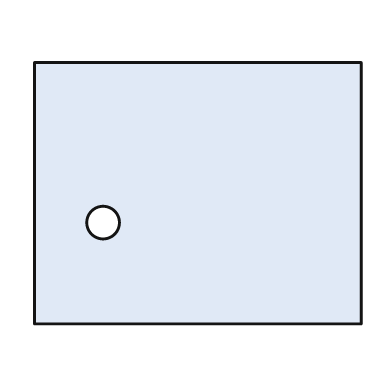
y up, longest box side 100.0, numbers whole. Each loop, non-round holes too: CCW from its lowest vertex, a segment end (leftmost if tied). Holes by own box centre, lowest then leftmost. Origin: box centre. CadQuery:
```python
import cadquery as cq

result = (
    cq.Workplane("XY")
    .moveTo(-50.0, -40.0)
    .lineTo(50.0, -40.0)
    .lineTo(50.0, 40.0)
    .lineTo(-50.0, 40.0)
    .close()
    .moveTo(-29.0, -9.0)
    .circle(5.0)
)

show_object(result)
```